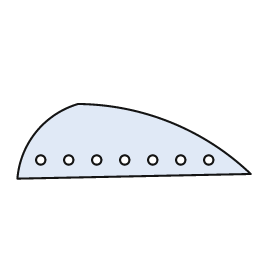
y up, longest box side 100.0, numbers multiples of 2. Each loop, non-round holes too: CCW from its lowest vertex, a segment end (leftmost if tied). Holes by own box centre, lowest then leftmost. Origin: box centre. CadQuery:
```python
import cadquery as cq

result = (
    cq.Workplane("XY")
    .moveTo(-50.0, -16.0)
    .lineTo(50.0, -14.0)
    .threePointArc((16.0, 8.0), (-24.0, 16.0))
    .threePointArc((-42.0, 4.0), (-50.0, -16.0))
    .close()
    .moveTo(-40.0, -8.0)
    .circle(2.0)
    .moveTo(-28.0, -8.0)
    .circle(2.0)
    .moveTo(-16.0, -8.0)
    .circle(2.0)
    .moveTo(-4.0, -8.0)
    .circle(2.0)
    .moveTo(8.0, -8.0)
    .circle(2.0)
    .moveTo(20.0, -8.0)
    .circle(2.0)
    .moveTo(32.0, -8.0)
    .circle(2.0)
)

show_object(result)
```